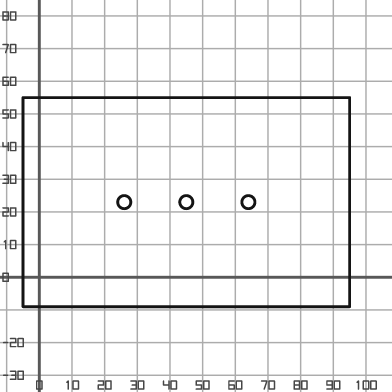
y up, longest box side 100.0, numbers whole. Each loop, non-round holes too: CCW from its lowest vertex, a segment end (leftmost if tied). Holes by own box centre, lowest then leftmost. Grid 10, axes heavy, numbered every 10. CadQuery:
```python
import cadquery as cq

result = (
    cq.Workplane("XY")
    .moveTo(-5.0, -9.0)
    .lineTo(95.0, -9.0)
    .lineTo(95.0, 55.0)
    .lineTo(-5.0, 55.0)
    .close()
    .moveTo(26.0, 23.0)
    .circle(2.0)
    .moveTo(45.0, 23.0)
    .circle(2.0)
    .moveTo(64.0, 23.0)
    .circle(2.0)
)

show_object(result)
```